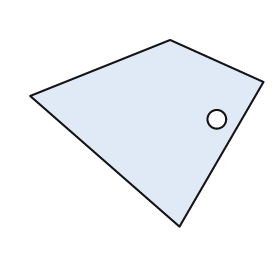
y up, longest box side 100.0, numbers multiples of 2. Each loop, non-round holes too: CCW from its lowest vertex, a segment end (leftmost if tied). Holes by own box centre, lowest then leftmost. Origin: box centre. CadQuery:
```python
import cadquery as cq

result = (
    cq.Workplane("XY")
    .moveTo(14.0, -40.0)
    .lineTo(50.0, 22.0)
    .lineTo(10.0, 40.0)
    .lineTo(-50.0, 16.0)
    .close()
    .moveTo(30.0, 6.0)
    .circle(4.0)
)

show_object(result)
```